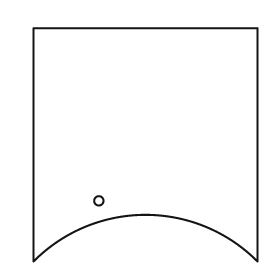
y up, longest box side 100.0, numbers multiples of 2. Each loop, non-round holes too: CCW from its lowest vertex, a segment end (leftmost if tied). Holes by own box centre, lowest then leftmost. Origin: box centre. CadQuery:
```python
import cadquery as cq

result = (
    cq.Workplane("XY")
    .moveTo(-48.0, -50.0)
    .threePointArc((0.0, -30.0), (48.0, -50.0))
    .lineTo(48.0, 50.0)
    .lineTo(-48.0, 50.0)
    .close()
    .moveTo(-20.0, -24.0)
    .circle(2.0)
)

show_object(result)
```